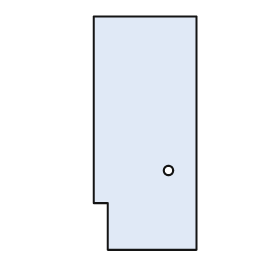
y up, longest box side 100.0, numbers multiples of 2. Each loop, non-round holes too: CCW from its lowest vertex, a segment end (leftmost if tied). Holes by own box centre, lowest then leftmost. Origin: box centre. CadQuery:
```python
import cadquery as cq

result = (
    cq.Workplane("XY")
    .moveTo(-16.0, -50.0)
    .lineTo(22.0, -50.0)
    .lineTo(22.0, 50.0)
    .lineTo(-22.0, 50.0)
    .lineTo(-22.0, -30.0)
    .lineTo(-16.0, -30.0)
    .close()
    .moveTo(10.0, -16.0)
    .circle(2.0)
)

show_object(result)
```